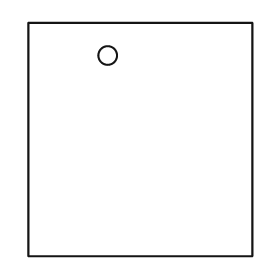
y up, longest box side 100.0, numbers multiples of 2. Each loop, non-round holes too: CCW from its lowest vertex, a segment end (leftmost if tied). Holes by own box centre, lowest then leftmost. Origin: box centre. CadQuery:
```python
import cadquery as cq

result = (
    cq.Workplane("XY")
    .moveTo(-48.0, -50.0)
    .lineTo(48.0, -50.0)
    .lineTo(48.0, 50.0)
    .lineTo(-48.0, 50.0)
    .close()
    .moveTo(-14.0, 36.0)
    .circle(4.0)
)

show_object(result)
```